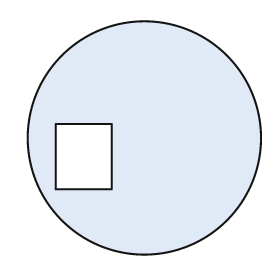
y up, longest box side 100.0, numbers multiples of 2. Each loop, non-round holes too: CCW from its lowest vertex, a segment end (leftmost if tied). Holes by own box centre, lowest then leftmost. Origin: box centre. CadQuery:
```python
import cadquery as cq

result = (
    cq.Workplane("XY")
    .moveTo(0.0, 0.0)
    .circle(50.0)
    .moveTo(-38.0, -22.0)
    .lineTo(-14.0, -22.0)
    .lineTo(-14.0, 6.0)
    .lineTo(-38.0, 6.0)
    .close()
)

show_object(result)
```